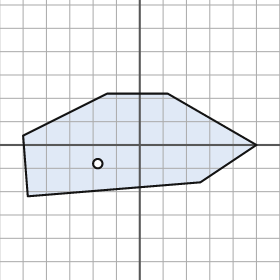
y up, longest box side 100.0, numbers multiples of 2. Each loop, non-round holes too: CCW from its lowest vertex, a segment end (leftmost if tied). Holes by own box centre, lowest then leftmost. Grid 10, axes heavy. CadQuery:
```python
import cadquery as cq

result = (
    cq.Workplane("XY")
    .moveTo(-48.0, -22.0)
    .lineTo(26.0, -16.0)
    .lineTo(50.0, 0.0)
    .lineTo(12.0, 22.0)
    .lineTo(-14.0, 22.0)
    .lineTo(-50.0, 4.0)
    .close()
    .moveTo(-18.0, -8.0)
    .circle(2.0)
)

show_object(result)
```